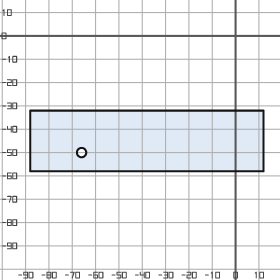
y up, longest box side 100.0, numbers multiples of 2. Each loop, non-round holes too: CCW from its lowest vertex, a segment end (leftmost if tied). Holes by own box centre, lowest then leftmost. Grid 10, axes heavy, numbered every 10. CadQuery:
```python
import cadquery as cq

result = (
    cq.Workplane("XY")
    .moveTo(-88.0, -58.0)
    .lineTo(12.0, -58.0)
    .lineTo(12.0, -32.0)
    .lineTo(-88.0, -32.0)
    .close()
    .moveTo(-66.0, -50.0)
    .circle(2.0)
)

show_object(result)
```